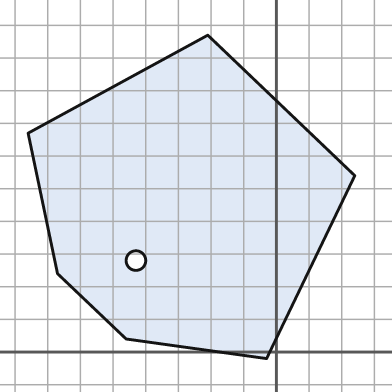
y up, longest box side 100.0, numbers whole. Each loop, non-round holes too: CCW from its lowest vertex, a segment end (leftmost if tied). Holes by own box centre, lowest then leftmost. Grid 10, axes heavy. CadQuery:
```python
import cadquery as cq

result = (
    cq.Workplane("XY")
    .moveTo(-3.0, -2.0)
    .lineTo(24.0, 54.0)
    .lineTo(-21.0, 97.0)
    .lineTo(-76.0, 67.0)
    .lineTo(-67.0, 24.0)
    .lineTo(-46.0, 4.0)
    .close()
    .moveTo(-43.0, 28.0)
    .circle(3.0)
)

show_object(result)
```